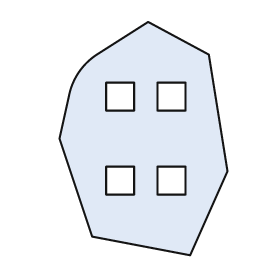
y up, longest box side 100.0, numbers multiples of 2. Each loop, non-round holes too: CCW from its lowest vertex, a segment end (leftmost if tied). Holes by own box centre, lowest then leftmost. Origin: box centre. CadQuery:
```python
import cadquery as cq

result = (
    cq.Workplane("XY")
    .moveTo(20.0, -50.0)
    .lineTo(36.0, -14.0)
    .lineTo(28.0, 36.0)
    .lineTo(2.0, 50.0)
    .lineTo(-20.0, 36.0)
    .threePointArc((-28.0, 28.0), (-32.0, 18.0))
    .lineTo(-36.0, 0.0)
    .lineTo(-22.0, -42.0)
    .close()
    .moveTo(-16.0, -24.0)
    .lineTo(-4.0, -24.0)
    .lineTo(-4.0, -12.0)
    .lineTo(-16.0, -12.0)
    .close()
    .moveTo(6.0, -24.0)
    .lineTo(18.0, -24.0)
    .lineTo(18.0, -12.0)
    .lineTo(6.0, -12.0)
    .close()
    .moveTo(-16.0, 12.0)
    .lineTo(-4.0, 12.0)
    .lineTo(-4.0, 24.0)
    .lineTo(-16.0, 24.0)
    .close()
    .moveTo(6.0, 12.0)
    .lineTo(18.0, 12.0)
    .lineTo(18.0, 24.0)
    .lineTo(6.0, 24.0)
    .close()
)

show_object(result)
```